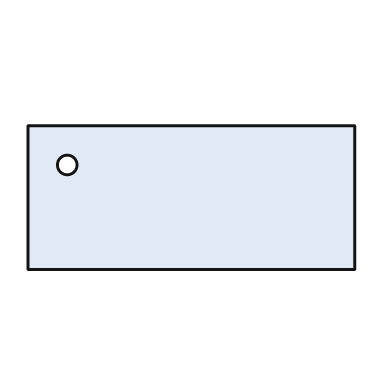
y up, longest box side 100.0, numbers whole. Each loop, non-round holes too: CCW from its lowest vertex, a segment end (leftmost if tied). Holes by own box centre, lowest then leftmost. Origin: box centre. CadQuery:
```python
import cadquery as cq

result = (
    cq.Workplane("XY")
    .moveTo(-50.0, -22.0)
    .lineTo(50.0, -22.0)
    .lineTo(50.0, 22.0)
    .lineTo(-50.0, 22.0)
    .close()
    .moveTo(-38.0, 10.0)
    .circle(3.0)
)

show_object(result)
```